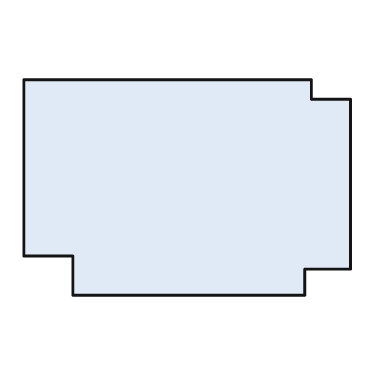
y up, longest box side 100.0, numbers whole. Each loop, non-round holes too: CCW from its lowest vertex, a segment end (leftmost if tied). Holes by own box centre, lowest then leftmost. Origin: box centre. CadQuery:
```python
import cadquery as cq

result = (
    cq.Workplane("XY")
    .moveTo(-35.0, -33.0)
    .lineTo(36.0, -33.0)
    .lineTo(36.0, -25.0)
    .lineTo(50.0, -25.0)
    .lineTo(50.0, 27.0)
    .lineTo(38.0, 27.0)
    .lineTo(38.0, 33.0)
    .lineTo(-50.0, 33.0)
    .lineTo(-50.0, -21.0)
    .lineTo(-35.0, -21.0)
    .close()
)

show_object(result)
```